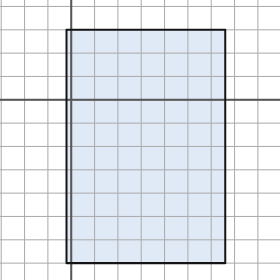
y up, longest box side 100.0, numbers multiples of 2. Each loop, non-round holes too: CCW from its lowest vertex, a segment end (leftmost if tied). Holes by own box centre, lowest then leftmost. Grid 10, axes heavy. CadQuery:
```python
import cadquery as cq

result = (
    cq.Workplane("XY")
    .moveTo(-2.0, -70.0)
    .lineTo(66.0, -70.0)
    .lineTo(66.0, 30.0)
    .lineTo(-2.0, 30.0)
    .close()
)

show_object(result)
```